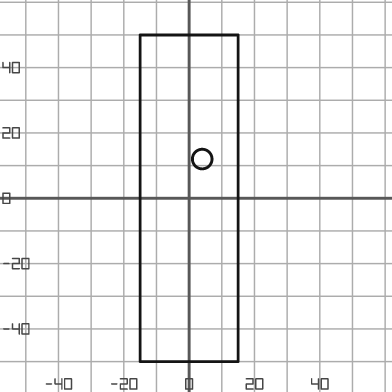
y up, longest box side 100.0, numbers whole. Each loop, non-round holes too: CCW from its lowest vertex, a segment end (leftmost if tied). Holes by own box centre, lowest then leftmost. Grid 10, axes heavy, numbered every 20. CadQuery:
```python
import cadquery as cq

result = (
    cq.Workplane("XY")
    .moveTo(-15.0, -50.0)
    .lineTo(15.0, -50.0)
    .lineTo(15.0, 50.0)
    .lineTo(-15.0, 50.0)
    .close()
    .moveTo(4.0, 12.0)
    .circle(3.0)
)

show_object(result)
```